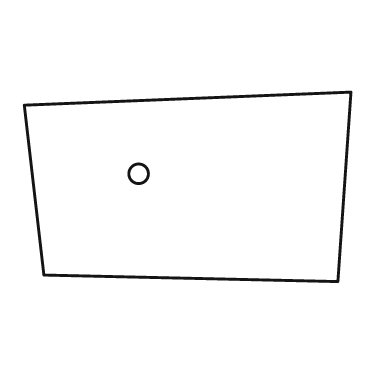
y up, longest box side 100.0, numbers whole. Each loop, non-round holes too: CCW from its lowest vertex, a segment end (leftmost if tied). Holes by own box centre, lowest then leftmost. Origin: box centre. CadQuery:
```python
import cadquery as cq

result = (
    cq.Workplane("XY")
    .moveTo(46.0, -29.0)
    .lineTo(50.0, 29.0)
    .lineTo(-50.0, 25.0)
    .lineTo(-44.0, -27.0)
    .close()
    .moveTo(-15.0, 4.0)
    .circle(3.0)
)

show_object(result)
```